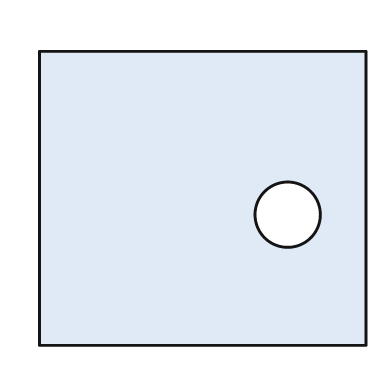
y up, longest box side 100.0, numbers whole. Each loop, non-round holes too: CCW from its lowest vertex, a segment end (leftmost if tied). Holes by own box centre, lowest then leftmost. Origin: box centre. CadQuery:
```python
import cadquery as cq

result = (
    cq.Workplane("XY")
    .moveTo(-50.0, -45.0)
    .lineTo(50.0, -45.0)
    .lineTo(50.0, 45.0)
    .lineTo(-50.0, 45.0)
    .close()
    .moveTo(26.0, -5.0)
    .circle(10.0)
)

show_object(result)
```